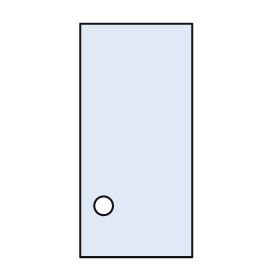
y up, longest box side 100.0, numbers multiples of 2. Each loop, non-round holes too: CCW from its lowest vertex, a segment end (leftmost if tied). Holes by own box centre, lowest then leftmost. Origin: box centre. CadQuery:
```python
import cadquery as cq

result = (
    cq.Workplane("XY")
    .moveTo(-24.0, -50.0)
    .lineTo(24.0, -50.0)
    .lineTo(24.0, 50.0)
    .lineTo(-24.0, 50.0)
    .close()
    .moveTo(-14.0, -28.0)
    .circle(4.0)
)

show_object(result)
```